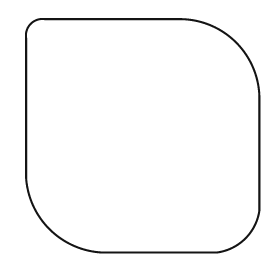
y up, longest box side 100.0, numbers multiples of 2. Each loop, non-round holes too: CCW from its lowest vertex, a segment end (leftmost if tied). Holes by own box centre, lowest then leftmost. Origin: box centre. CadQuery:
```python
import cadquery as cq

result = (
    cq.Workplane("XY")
    .moveTo(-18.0, -50.0)
    .lineTo(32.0, -50.0)
    .threePointArc((44.0, -44.0), (50.0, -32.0))
    .lineTo(50.0, 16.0)
    .threePointArc((40.0, 40.0), (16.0, 50.0))
    .lineTo(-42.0, 50.0)
    .threePointArc((-48.0, 48.0), (-50.0, 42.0))
    .lineTo(-50.0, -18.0)
    .threePointArc((-40.0, -40.0), (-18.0, -50.0))
    .close()
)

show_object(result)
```